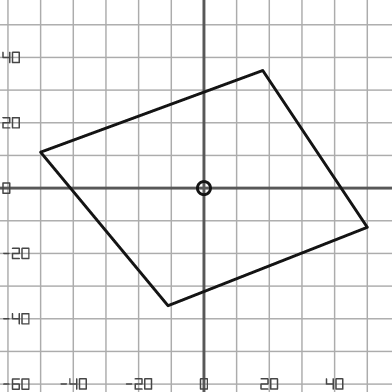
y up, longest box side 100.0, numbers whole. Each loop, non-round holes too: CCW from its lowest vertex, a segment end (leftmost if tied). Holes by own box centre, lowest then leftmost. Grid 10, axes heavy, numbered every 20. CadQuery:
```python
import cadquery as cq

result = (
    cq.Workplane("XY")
    .moveTo(-11.0, -36.0)
    .lineTo(50.0, -12.0)
    .lineTo(18.0, 36.0)
    .lineTo(-50.0, 11.0)
    .close()
    .moveTo(0.0, 0.0)
    .circle(2.0)
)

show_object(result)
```